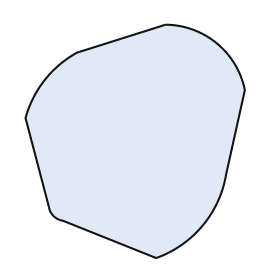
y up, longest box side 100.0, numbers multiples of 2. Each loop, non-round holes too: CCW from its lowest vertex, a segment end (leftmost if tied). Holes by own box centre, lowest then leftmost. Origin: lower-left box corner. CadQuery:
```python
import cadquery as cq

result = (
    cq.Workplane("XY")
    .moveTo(56.0, 0.0)
    .threePointArc((76.0, 14.0), (86.0, 36.0))
    .lineTo(94.0, 72.0)
    .threePointArc((82.0, 92.0), (60.0, 100.0))
    .lineTo(22.0, 88.0)
    .threePointArc((8.0, 76.0), (0.0, 60.0))
    .lineTo(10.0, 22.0)
    .threePointArc((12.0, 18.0), (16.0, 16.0))
    .close()
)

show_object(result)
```